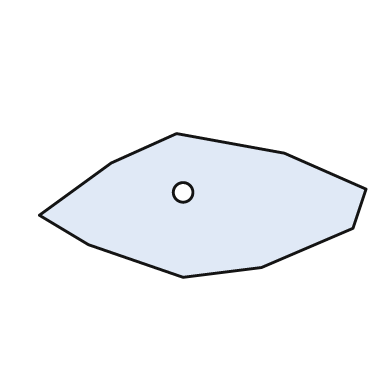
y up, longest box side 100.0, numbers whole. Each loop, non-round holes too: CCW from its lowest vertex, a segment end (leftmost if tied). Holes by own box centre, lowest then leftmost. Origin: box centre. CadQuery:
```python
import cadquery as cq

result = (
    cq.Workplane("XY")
    .moveTo(-6.0, -22.0)
    .lineTo(18.0, -19.0)
    .lineTo(46.0, -7.0)
    .lineTo(50.0, 5.0)
    .lineTo(25.0, 16.0)
    .lineTo(-8.0, 22.0)
    .lineTo(-28.0, 13.0)
    .lineTo(-50.0, -3.0)
    .lineTo(-35.0, -12.0)
    .close()
    .moveTo(-6.0, 4.0)
    .circle(3.0)
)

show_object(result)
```